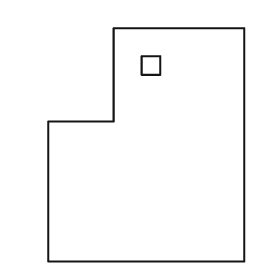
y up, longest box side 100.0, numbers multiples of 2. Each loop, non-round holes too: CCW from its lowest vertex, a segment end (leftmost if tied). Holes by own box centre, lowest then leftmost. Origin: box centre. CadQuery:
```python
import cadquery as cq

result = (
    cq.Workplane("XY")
    .moveTo(-42.0, -50.0)
    .lineTo(42.0, -50.0)
    .lineTo(42.0, 50.0)
    .lineTo(-14.0, 50.0)
    .lineTo(-14.0, 10.0)
    .lineTo(-42.0, 10.0)
    .close()
    .moveTo(-2.0, 30.0)
    .lineTo(6.0, 30.0)
    .lineTo(6.0, 38.0)
    .lineTo(-2.0, 38.0)
    .close()
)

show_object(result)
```